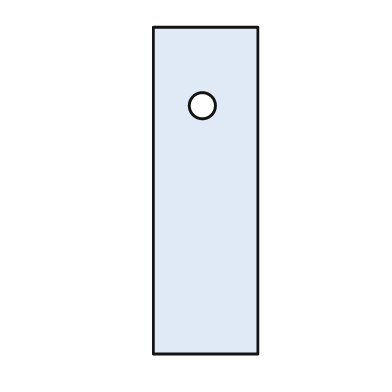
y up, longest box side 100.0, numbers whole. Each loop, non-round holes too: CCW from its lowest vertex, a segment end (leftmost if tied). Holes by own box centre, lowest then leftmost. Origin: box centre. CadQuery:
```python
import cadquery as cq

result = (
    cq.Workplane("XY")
    .moveTo(-16.0, -50.0)
    .lineTo(16.0, -50.0)
    .lineTo(16.0, 50.0)
    .lineTo(-16.0, 50.0)
    .close()
    .moveTo(-1.0, 26.0)
    .circle(4.0)
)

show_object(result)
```